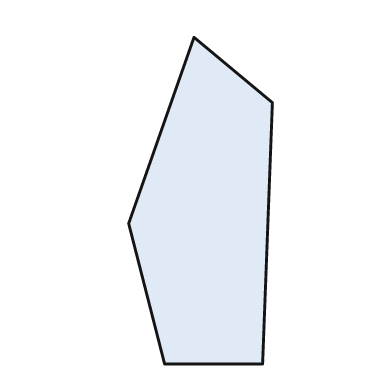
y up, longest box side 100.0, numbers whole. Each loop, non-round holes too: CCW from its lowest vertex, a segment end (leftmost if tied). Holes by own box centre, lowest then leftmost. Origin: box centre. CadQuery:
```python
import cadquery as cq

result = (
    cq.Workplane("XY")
    .moveTo(-11.0, -50.0)
    .lineTo(19.0, -50.0)
    .lineTo(22.0, 30.0)
    .lineTo(-2.0, 50.0)
    .lineTo(-22.0, -7.0)
    .close()
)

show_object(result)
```